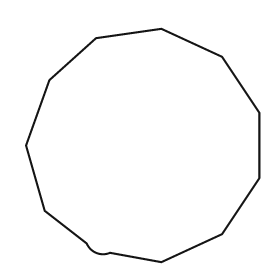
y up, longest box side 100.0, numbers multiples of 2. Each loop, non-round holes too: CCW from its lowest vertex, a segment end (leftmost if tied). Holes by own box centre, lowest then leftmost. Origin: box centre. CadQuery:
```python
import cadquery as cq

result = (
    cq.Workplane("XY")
    .moveTo(8.0, -50.0)
    .lineTo(34.0, -38.0)
    .lineTo(50.0, -14.0)
    .lineTo(50.0, 14.0)
    .lineTo(34.0, 38.0)
    .lineTo(8.0, 50.0)
    .lineTo(-20.0, 46.0)
    .lineTo(-40.0, 28.0)
    .lineTo(-50.0, 0.0)
    .lineTo(-42.0, -28.0)
    .lineTo(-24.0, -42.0)
    .threePointArc((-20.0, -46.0), (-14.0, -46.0))
    .close()
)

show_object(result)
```